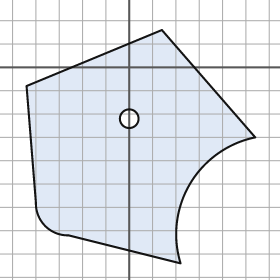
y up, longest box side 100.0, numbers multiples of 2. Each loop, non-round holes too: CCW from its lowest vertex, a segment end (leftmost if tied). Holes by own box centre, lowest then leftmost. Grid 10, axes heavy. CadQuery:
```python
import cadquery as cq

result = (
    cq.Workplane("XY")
    .moveTo(22.0, -84.0)
    .threePointArc((26.0, -50.0), (54.0, -30.0))
    .lineTo(14.0, 16.0)
    .lineTo(-44.0, -8.0)
    .lineTo(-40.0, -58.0)
    .threePointArc((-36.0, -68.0), (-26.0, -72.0))
    .close()
    .moveTo(0.0, -22.0)
    .circle(4.0)
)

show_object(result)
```